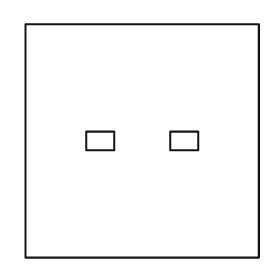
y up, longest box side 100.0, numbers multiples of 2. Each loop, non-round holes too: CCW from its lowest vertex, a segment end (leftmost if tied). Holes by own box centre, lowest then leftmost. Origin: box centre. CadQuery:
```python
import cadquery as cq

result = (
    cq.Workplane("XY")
    .moveTo(-50.0, -50.0)
    .lineTo(50.0, -50.0)
    .lineTo(50.0, 50.0)
    .lineTo(-50.0, 50.0)
    .close()
    .moveTo(-24.0, -4.0)
    .lineTo(-12.0, -4.0)
    .lineTo(-12.0, 4.0)
    .lineTo(-24.0, 4.0)
    .close()
    .moveTo(12.0, -4.0)
    .lineTo(24.0, -4.0)
    .lineTo(24.0, 4.0)
    .lineTo(12.0, 4.0)
    .close()
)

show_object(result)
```